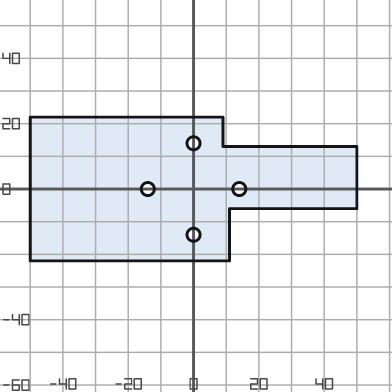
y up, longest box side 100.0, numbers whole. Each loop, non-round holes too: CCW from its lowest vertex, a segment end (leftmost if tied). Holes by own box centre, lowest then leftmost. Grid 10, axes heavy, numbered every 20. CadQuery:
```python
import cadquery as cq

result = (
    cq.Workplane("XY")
    .moveTo(-50.0, -22.0)
    .lineTo(11.0, -22.0)
    .lineTo(11.0, -6.0)
    .lineTo(50.0, -6.0)
    .lineTo(50.0, 13.0)
    .lineTo(9.0, 13.0)
    .lineTo(9.0, 22.0)
    .lineTo(-50.0, 22.0)
    .close()
    .moveTo(0.0, -14.0)
    .circle(2.0)
    .moveTo(-14.0, 0.0)
    .circle(2.0)
    .moveTo(14.0, 0.0)
    .circle(2.0)
    .moveTo(0.0, 14.0)
    .circle(2.0)
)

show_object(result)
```